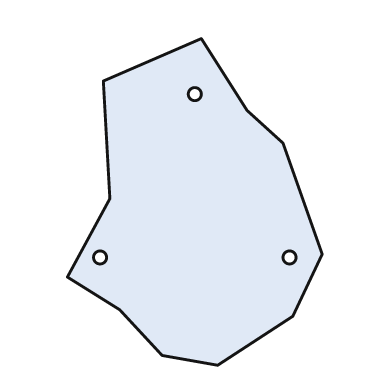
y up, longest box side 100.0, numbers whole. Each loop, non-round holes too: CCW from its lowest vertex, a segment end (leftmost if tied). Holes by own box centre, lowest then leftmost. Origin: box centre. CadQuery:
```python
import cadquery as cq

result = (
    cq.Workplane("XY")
    .moveTo(7.0, -50.0)
    .lineTo(30.0, -35.0)
    .lineTo(39.0, -16.0)
    .lineTo(27.0, 18.0)
    .lineTo(16.0, 28.0)
    .lineTo(2.0, 50.0)
    .lineTo(-28.0, 37.0)
    .lineTo(-26.0, 1.0)
    .lineTo(-39.0, -23.0)
    .lineTo(-23.0, -33.0)
    .lineTo(-10.0, -47.0)
    .close()
    .moveTo(-29.0, -17.0)
    .circle(2.0)
    .moveTo(29.0, -17.0)
    .circle(2.0)
    .moveTo(0.0, 33.0)
    .circle(2.0)
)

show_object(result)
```